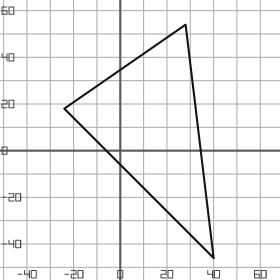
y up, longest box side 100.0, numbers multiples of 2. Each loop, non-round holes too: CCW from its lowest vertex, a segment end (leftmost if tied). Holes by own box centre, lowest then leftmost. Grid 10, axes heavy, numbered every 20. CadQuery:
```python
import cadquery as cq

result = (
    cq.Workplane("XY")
    .moveTo(40.0, -46.0)
    .lineTo(28.0, 54.0)
    .lineTo(-24.0, 18.0)
    .close()
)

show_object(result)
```